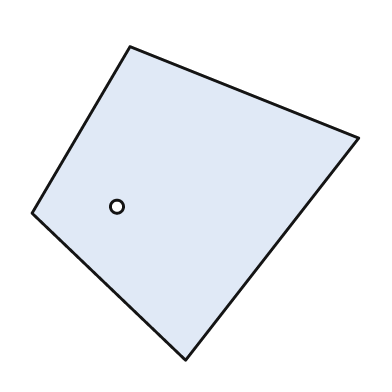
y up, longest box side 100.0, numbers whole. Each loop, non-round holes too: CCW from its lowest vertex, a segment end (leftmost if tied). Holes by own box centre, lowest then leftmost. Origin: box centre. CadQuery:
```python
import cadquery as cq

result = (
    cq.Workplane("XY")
    .moveTo(-3.0, -48.0)
    .lineTo(50.0, 20.0)
    .lineTo(-20.0, 48.0)
    .lineTo(-50.0, -3.0)
    .close()
    .moveTo(-24.0, -1.0)
    .circle(2.0)
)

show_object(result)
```